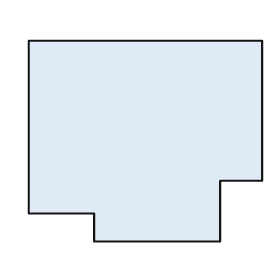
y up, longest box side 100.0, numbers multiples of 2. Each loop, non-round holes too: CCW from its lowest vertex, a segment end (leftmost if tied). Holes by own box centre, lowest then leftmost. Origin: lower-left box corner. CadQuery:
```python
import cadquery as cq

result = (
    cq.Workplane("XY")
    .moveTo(28.0, 0.0)
    .lineTo(82.0, 0.0)
    .lineTo(82.0, 26.0)
    .lineTo(100.0, 26.0)
    .lineTo(100.0, 86.0)
    .lineTo(0.0, 86.0)
    .lineTo(0.0, 12.0)
    .lineTo(28.0, 12.0)
    .close()
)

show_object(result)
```